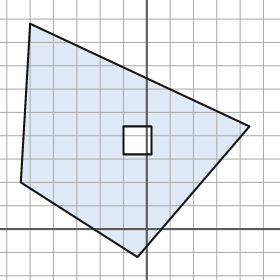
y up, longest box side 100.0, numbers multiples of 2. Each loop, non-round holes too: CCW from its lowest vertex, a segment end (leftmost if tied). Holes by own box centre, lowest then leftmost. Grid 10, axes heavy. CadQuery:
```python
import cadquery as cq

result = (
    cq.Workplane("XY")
    .moveTo(-4.0, -12.0)
    .lineTo(44.0, 44.0)
    .lineTo(-50.0, 88.0)
    .lineTo(-54.0, 20.0)
    .close()
    .moveTo(-10.0, 32.0)
    .lineTo(2.0, 32.0)
    .lineTo(2.0, 44.0)
    .lineTo(-10.0, 44.0)
    .close()
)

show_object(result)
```